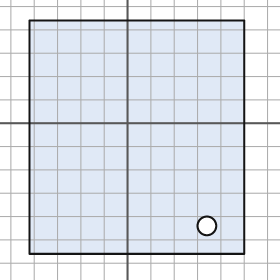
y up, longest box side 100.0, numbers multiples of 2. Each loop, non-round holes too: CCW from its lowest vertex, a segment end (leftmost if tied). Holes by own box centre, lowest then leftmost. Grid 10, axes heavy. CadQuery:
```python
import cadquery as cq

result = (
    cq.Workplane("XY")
    .moveTo(-42.0, -56.0)
    .lineTo(50.0, -56.0)
    .lineTo(50.0, 44.0)
    .lineTo(-42.0, 44.0)
    .close()
    .moveTo(34.0, -44.0)
    .circle(4.0)
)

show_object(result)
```